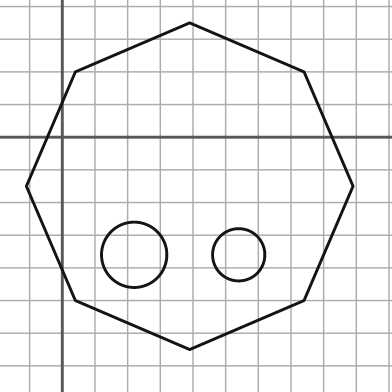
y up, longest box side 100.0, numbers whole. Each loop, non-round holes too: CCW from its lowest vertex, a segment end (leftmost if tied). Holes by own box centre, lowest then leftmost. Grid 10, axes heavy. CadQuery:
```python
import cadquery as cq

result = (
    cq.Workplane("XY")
    .moveTo(39.0, -65.0)
    .lineTo(74.0, -50.0)
    .lineTo(89.0, -15.0)
    .lineTo(74.0, 20.0)
    .lineTo(39.0, 35.0)
    .lineTo(4.0, 20.0)
    .lineTo(-11.0, -15.0)
    .lineTo(4.0, -50.0)
    .close()
    .moveTo(22.0, -36.0)
    .circle(10.0)
    .moveTo(54.0, -36.0)
    .circle(8.0)
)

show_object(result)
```